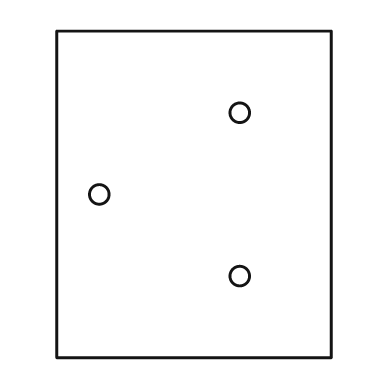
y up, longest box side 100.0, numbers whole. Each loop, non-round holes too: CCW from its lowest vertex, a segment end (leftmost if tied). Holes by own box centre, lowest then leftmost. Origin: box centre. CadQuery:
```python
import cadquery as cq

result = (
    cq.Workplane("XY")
    .moveTo(-42.0, -50.0)
    .lineTo(42.0, -50.0)
    .lineTo(42.0, 50.0)
    .lineTo(-42.0, 50.0)
    .close()
    .moveTo(14.0, -25.0)
    .circle(3.0)
    .moveTo(-29.0, 0.0)
    .circle(3.0)
    .moveTo(14.0, 25.0)
    .circle(3.0)
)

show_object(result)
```